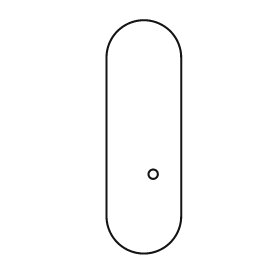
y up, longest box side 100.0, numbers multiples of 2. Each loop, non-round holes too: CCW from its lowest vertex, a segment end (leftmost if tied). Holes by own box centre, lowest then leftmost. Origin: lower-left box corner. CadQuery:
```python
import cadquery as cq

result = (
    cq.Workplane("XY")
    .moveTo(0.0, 16.0)
    .threePointArc((16.0, 0.0), (32.0, 16.0))
    .lineTo(32.0, 84.0)
    .threePointArc((16.0, 100.0), (0.0, 84.0))
    .close()
    .moveTo(20.0, 34.0)
    .circle(2.0)
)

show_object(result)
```